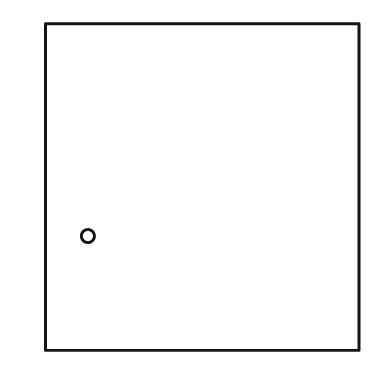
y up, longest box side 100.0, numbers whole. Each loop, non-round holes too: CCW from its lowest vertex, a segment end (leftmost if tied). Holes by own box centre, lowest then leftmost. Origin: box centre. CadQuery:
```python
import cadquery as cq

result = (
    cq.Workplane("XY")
    .moveTo(-48.0, -50.0)
    .lineTo(48.0, -50.0)
    .lineTo(48.0, 50.0)
    .lineTo(-48.0, 50.0)
    .close()
    .moveTo(-35.0, -15.0)
    .circle(2.0)
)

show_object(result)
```